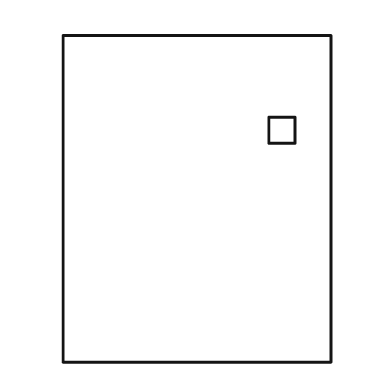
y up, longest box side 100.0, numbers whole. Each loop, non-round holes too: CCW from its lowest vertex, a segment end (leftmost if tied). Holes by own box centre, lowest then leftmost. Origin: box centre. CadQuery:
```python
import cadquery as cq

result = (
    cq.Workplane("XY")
    .moveTo(-41.0, -50.0)
    .lineTo(41.0, -50.0)
    .lineTo(41.0, 50.0)
    .lineTo(-41.0, 50.0)
    .close()
    .moveTo(22.0, 17.0)
    .lineTo(30.0, 17.0)
    .lineTo(30.0, 25.0)
    .lineTo(22.0, 25.0)
    .close()
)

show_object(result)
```